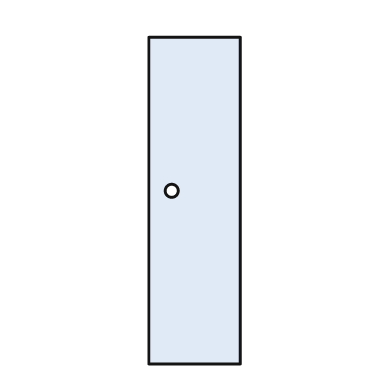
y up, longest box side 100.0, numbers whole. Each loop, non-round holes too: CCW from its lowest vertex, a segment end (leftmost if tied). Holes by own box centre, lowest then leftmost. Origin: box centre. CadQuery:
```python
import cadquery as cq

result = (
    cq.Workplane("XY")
    .moveTo(-14.0, -50.0)
    .lineTo(14.0, -50.0)
    .lineTo(14.0, 50.0)
    .lineTo(-14.0, 50.0)
    .close()
    .moveTo(-7.0, 3.0)
    .circle(2.0)
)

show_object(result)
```